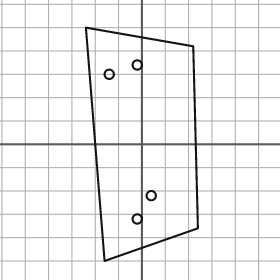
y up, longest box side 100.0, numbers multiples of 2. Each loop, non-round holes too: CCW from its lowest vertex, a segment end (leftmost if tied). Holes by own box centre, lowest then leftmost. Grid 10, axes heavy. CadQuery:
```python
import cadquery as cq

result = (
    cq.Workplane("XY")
    .moveTo(-16.0, -50.0)
    .lineTo(24.0, -36.0)
    .lineTo(22.0, 42.0)
    .lineTo(-24.0, 50.0)
    .close()
    .moveTo(-2.0, -32.0)
    .circle(2.0)
    .moveTo(4.0, -22.0)
    .circle(2.0)
    .moveTo(-14.0, 30.0)
    .circle(2.0)
    .moveTo(-2.0, 34.0)
    .circle(2.0)
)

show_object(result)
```